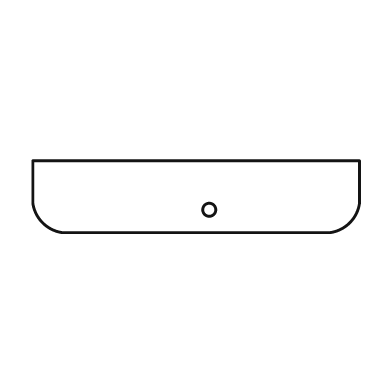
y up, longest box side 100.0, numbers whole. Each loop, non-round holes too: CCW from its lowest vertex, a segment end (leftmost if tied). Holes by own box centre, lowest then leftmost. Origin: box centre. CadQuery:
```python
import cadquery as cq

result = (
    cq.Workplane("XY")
    .moveTo(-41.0, -11.0)
    .lineTo(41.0, -11.0)
    .threePointArc((47.0, -8.0), (50.0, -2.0))
    .lineTo(50.0, 11.0)
    .lineTo(-50.0, 11.0)
    .lineTo(-50.0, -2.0)
    .threePointArc((-47.0, -8.0), (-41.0, -11.0))
    .close()
    .moveTo(4.0, -4.0)
    .circle(2.0)
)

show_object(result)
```